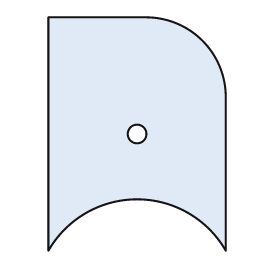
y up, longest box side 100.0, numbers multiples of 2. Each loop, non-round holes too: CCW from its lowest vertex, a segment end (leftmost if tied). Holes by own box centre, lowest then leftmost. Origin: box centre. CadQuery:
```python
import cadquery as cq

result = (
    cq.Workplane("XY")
    .moveTo(-38.0, -50.0)
    .threePointArc((0.0, -28.0), (38.0, -50.0))
    .lineTo(38.0, 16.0)
    .threePointArc((28.0, 40.0), (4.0, 50.0))
    .lineTo(-38.0, 50.0)
    .close()
    .moveTo(0.0, 0.0)
    .circle(4.0)
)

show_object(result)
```